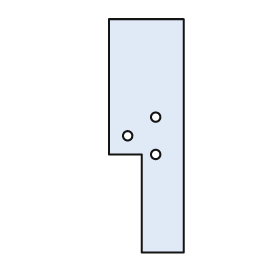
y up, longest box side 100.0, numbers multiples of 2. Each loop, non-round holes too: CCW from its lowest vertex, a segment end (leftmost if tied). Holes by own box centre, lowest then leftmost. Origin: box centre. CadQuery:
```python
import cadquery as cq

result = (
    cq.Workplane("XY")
    .moveTo(-2.0, -50.0)
    .lineTo(16.0, -50.0)
    .lineTo(16.0, 50.0)
    .lineTo(-16.0, 50.0)
    .lineTo(-16.0, -8.0)
    .lineTo(-2.0, -8.0)
    .close()
    .moveTo(4.0, -8.0)
    .circle(2.0)
    .moveTo(-8.0, 0.0)
    .circle(2.0)
    .moveTo(4.0, 8.0)
    .circle(2.0)
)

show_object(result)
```